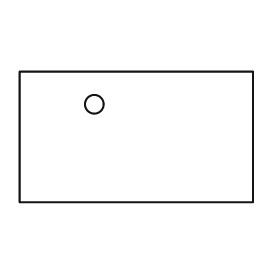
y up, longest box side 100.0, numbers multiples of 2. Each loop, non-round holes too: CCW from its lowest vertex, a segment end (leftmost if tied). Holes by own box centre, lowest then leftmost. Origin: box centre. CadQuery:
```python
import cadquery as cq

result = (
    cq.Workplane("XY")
    .moveTo(-50.0, -28.0)
    .lineTo(50.0, -28.0)
    .lineTo(50.0, 28.0)
    .lineTo(-50.0, 28.0)
    .close()
    .moveTo(-18.0, 14.0)
    .circle(4.0)
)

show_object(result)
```